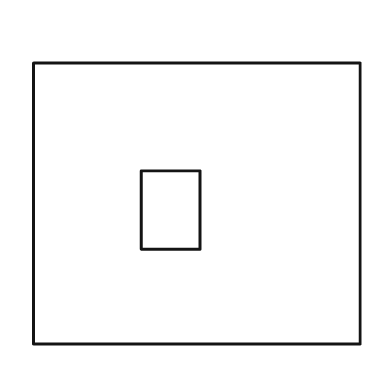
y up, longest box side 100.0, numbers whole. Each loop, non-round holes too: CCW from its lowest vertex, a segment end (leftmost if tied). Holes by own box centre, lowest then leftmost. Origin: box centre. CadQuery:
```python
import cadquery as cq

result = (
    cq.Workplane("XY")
    .moveTo(-50.0, -43.0)
    .lineTo(50.0, -43.0)
    .lineTo(50.0, 43.0)
    .lineTo(-50.0, 43.0)
    .close()
    .moveTo(-17.0, -14.0)
    .lineTo(1.0, -14.0)
    .lineTo(1.0, 10.0)
    .lineTo(-17.0, 10.0)
    .close()
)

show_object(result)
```